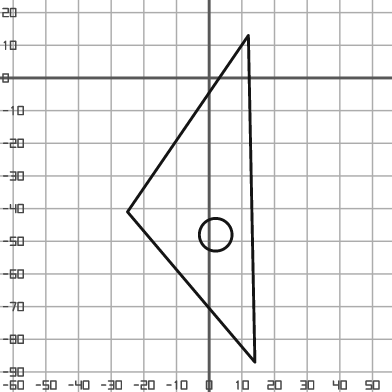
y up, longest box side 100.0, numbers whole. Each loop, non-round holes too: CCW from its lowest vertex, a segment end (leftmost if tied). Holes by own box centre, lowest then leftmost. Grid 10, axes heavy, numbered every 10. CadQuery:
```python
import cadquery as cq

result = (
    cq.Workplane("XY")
    .moveTo(14.0, -87.0)
    .lineTo(12.0, 13.0)
    .lineTo(-25.0, -41.0)
    .close()
    .moveTo(2.0, -48.0)
    .circle(5.0)
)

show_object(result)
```